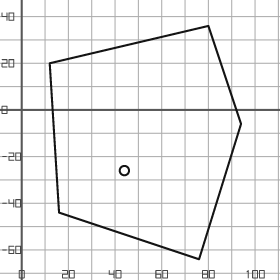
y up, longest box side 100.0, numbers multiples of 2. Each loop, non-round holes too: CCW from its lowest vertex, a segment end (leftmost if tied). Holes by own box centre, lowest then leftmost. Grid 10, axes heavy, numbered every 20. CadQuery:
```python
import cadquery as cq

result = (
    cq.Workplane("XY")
    .moveTo(76.0, -64.0)
    .lineTo(94.0, -6.0)
    .lineTo(80.0, 36.0)
    .lineTo(12.0, 20.0)
    .lineTo(16.0, -44.0)
    .close()
    .moveTo(44.0, -26.0)
    .circle(2.0)
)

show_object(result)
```